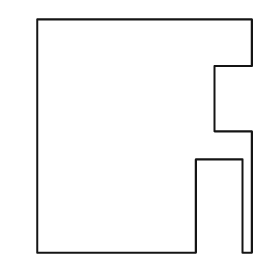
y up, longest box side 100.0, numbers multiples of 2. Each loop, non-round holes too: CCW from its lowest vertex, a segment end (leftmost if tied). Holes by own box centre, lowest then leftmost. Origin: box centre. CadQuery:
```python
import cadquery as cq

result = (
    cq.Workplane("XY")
    .moveTo(-46.0, -50.0)
    .lineTo(22.0, -50.0)
    .lineTo(22.0, -10.0)
    .lineTo(42.0, -10.0)
    .lineTo(42.0, -50.0)
    .lineTo(46.0, -50.0)
    .lineTo(46.0, 2.0)
    .lineTo(30.0, 2.0)
    .lineTo(30.0, 30.0)
    .lineTo(46.0, 30.0)
    .lineTo(46.0, 50.0)
    .lineTo(-46.0, 50.0)
    .close()
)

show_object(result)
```